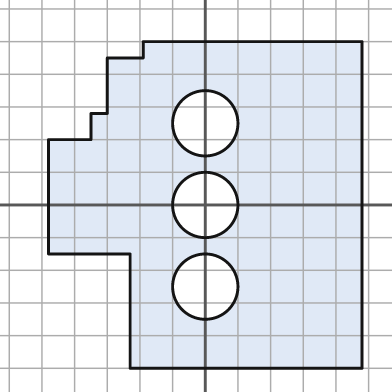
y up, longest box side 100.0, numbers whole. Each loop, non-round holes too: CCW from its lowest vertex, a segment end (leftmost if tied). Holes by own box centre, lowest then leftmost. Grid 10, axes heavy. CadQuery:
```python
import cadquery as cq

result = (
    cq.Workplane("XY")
    .moveTo(-23.0, -50.0)
    .lineTo(48.0, -50.0)
    .lineTo(48.0, 50.0)
    .lineTo(-19.0, 50.0)
    .lineTo(-19.0, 45.0)
    .lineTo(-30.0, 45.0)
    .lineTo(-30.0, 28.0)
    .lineTo(-35.0, 28.0)
    .lineTo(-35.0, 20.0)
    .lineTo(-48.0, 20.0)
    .lineTo(-48.0, -15.0)
    .lineTo(-23.0, -15.0)
    .close()
    .moveTo(0.0, -25.0)
    .circle(10.0)
    .moveTo(0.0, 0.0)
    .circle(10.0)
    .moveTo(0.0, 25.0)
    .circle(10.0)
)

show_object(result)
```